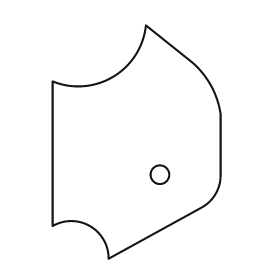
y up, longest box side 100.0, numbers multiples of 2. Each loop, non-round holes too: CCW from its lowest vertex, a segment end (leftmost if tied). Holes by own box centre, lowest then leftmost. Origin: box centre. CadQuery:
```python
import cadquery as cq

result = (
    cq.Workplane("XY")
    .moveTo(-12.0, -50.0)
    .lineTo(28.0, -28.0)
    .threePointArc((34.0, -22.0), (36.0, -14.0))
    .lineTo(36.0, 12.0)
    .threePointArc((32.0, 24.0), (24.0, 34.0))
    .lineTo(4.0, 50.0)
    .threePointArc((-10.0, 28.0), (-36.0, 26.0))
    .lineTo(-36.0, -36.0)
    .threePointArc((-20.0, -36.0), (-12.0, -50.0))
    .close()
    .moveTo(10.0, -14.0)
    .circle(4.0)
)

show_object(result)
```